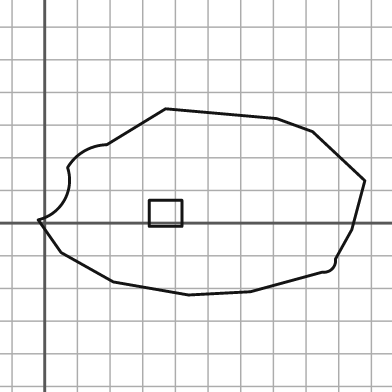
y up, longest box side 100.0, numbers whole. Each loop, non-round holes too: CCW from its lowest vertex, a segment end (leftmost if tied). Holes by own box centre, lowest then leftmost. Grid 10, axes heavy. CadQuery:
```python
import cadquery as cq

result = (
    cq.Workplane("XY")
    .moveTo(44.0, -22.0)
    .lineTo(63.0, -21.0)
    .lineTo(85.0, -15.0)
    .threePointArc((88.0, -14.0), (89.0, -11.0))
    .lineTo(94.0, -2.0)
    .lineTo(98.0, 13.0)
    .lineTo(82.0, 28.0)
    .lineTo(71.0, 32.0)
    .lineTo(37.0, 35.0)
    .lineTo(19.0, 24.0)
    .threePointArc((12.0, 22.0), (7.0, 17.0))
    .threePointArc((6.0, 7.0), (-2.0, 1.0))
    .lineTo(5.0, -9.0)
    .lineTo(21.0, -18.0)
    .close()
    .moveTo(32.0, -1.0)
    .lineTo(42.0, -1.0)
    .lineTo(42.0, 7.0)
    .lineTo(32.0, 7.0)
    .close()
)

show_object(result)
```